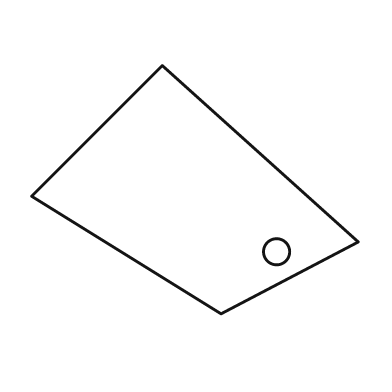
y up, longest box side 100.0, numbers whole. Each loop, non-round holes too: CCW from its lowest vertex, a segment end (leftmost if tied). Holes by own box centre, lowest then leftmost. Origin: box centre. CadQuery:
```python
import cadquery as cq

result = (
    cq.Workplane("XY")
    .moveTo(8.0, -38.0)
    .lineTo(50.0, -16.0)
    .lineTo(-10.0, 38.0)
    .lineTo(-50.0, -2.0)
    .close()
    .moveTo(25.0, -19.0)
    .circle(4.0)
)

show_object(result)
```